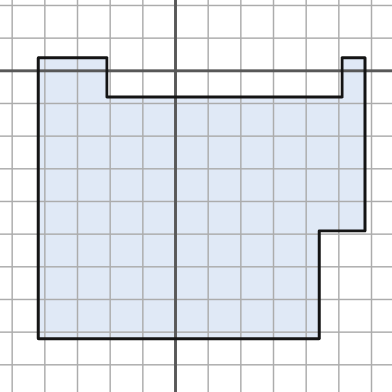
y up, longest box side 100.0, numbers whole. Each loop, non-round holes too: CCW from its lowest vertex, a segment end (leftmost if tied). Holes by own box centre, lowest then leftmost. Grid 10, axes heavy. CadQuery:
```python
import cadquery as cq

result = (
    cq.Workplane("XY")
    .moveTo(-42.0, -82.0)
    .lineTo(44.0, -82.0)
    .lineTo(44.0, -49.0)
    .lineTo(58.0, -49.0)
    .lineTo(58.0, 4.0)
    .lineTo(51.0, 4.0)
    .lineTo(51.0, -8.0)
    .lineTo(-21.0, -8.0)
    .lineTo(-21.0, 4.0)
    .lineTo(-42.0, 4.0)
    .close()
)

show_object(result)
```